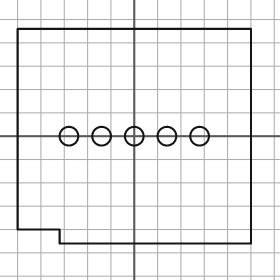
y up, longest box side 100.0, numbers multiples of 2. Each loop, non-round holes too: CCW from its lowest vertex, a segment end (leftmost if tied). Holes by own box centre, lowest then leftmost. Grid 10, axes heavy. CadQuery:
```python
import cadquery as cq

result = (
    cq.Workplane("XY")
    .moveTo(-32.0, -46.0)
    .lineTo(50.0, -46.0)
    .lineTo(50.0, 46.0)
    .lineTo(-50.0, 46.0)
    .lineTo(-50.0, -40.0)
    .lineTo(-32.0, -40.0)
    .close()
    .moveTo(-28.0, 0.0)
    .circle(4.0)
    .moveTo(-14.0, 0.0)
    .circle(4.0)
    .moveTo(0.0, 0.0)
    .circle(4.0)
    .moveTo(14.0, 0.0)
    .circle(4.0)
    .moveTo(28.0, 0.0)
    .circle(4.0)
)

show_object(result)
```